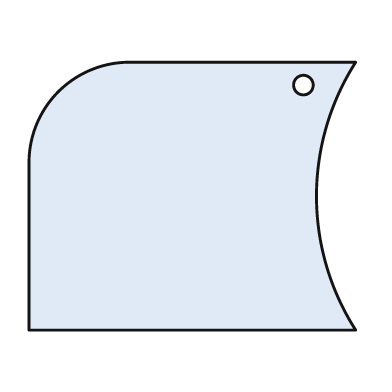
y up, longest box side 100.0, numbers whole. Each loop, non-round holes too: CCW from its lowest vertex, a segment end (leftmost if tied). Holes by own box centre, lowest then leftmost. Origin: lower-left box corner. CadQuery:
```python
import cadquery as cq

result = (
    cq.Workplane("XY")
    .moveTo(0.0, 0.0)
    .lineTo(100.0, 0.0)
    .threePointArc((88.0, 41.0), (100.0, 82.0))
    .lineTo(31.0, 82.0)
    .threePointArc((9.0, 73.0), (0.0, 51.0))
    .close()
    .moveTo(84.0, 75.0)
    .circle(3.0)
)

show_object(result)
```